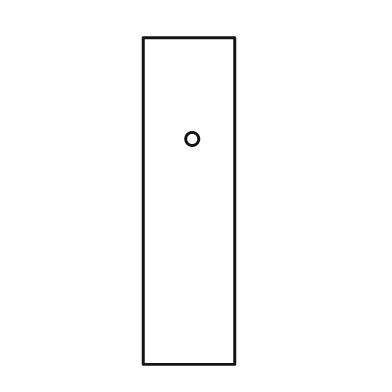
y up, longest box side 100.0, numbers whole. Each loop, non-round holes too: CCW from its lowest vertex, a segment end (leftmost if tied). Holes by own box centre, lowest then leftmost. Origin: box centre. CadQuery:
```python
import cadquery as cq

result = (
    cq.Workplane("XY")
    .moveTo(-14.0, -50.0)
    .lineTo(14.0, -50.0)
    .lineTo(14.0, 50.0)
    .lineTo(-14.0, 50.0)
    .close()
    .moveTo(1.0, 19.0)
    .circle(2.0)
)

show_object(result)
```